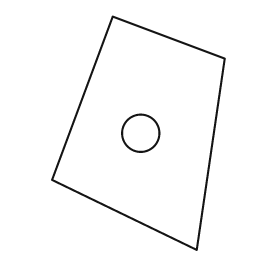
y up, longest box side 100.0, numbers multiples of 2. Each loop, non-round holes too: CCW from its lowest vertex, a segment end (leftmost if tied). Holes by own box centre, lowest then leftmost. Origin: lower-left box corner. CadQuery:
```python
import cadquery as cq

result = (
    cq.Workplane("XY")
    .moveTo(62.0, 0.0)
    .lineTo(74.0, 82.0)
    .lineTo(26.0, 100.0)
    .lineTo(0.0, 30.0)
    .close()
    .moveTo(38.0, 50.0)
    .circle(8.0)
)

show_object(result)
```